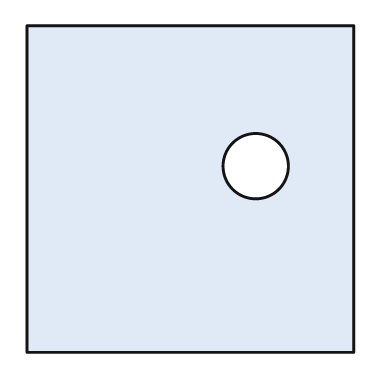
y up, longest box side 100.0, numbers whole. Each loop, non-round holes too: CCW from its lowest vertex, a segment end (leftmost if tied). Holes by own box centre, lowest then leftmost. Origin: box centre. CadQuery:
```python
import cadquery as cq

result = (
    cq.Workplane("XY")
    .moveTo(-50.0, -50.0)
    .lineTo(50.0, -50.0)
    .lineTo(50.0, 50.0)
    .lineTo(-50.0, 50.0)
    .close()
    .moveTo(20.0, 7.0)
    .circle(10.0)
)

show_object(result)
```